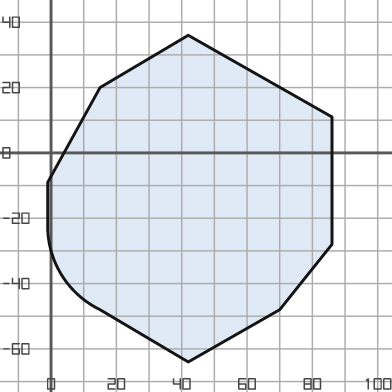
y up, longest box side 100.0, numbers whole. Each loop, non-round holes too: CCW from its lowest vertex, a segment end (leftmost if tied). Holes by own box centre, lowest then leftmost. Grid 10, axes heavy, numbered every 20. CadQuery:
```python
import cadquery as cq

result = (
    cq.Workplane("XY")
    .moveTo(42.0, -64.0)
    .lineTo(70.0, -48.0)
    .lineTo(86.0, -28.0)
    .lineTo(86.0, 11.0)
    .lineTo(42.0, 36.0)
    .lineTo(15.0, 20.0)
    .lineTo(-1.0, -9.0)
    .lineTo(-1.0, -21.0)
    .threePointArc((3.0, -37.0), (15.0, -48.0))
    .close()
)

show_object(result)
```